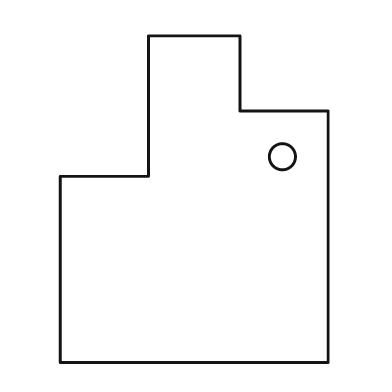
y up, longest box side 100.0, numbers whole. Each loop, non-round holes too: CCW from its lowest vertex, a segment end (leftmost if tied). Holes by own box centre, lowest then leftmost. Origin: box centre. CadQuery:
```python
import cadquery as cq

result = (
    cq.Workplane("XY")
    .moveTo(-41.0, -50.0)
    .lineTo(41.0, -50.0)
    .lineTo(41.0, 27.0)
    .lineTo(14.0, 27.0)
    .lineTo(14.0, 50.0)
    .lineTo(-14.0, 50.0)
    .lineTo(-14.0, 7.0)
    .lineTo(-41.0, 7.0)
    .close()
    .moveTo(27.0, 13.0)
    .circle(4.0)
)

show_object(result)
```